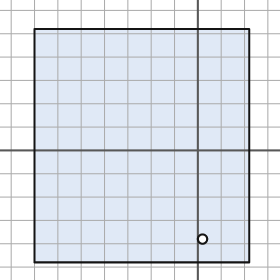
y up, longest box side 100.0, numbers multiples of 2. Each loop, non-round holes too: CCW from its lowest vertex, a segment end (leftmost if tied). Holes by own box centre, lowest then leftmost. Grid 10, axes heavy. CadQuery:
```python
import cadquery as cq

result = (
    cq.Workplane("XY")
    .moveTo(-70.0, -48.0)
    .lineTo(22.0, -48.0)
    .lineTo(22.0, 52.0)
    .lineTo(-70.0, 52.0)
    .close()
    .moveTo(2.0, -38.0)
    .circle(2.0)
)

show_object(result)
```